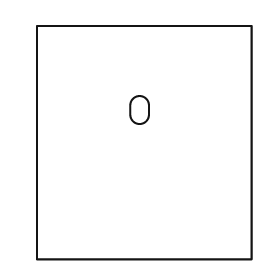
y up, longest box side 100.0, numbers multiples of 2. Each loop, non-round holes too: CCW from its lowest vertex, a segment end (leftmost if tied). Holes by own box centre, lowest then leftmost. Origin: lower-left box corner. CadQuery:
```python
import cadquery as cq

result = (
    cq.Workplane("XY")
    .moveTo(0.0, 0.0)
    .lineTo(92.0, 0.0)
    .lineTo(92.0, 100.0)
    .lineTo(0.0, 100.0)
    .close()
    .moveTo(40.0, 62.0)
    .threePointArc((44.0, 58.0), (48.0, 62.0))
    .lineTo(48.0, 66.0)
    .threePointArc((44.0, 70.0), (40.0, 66.0))
    .close()
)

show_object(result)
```